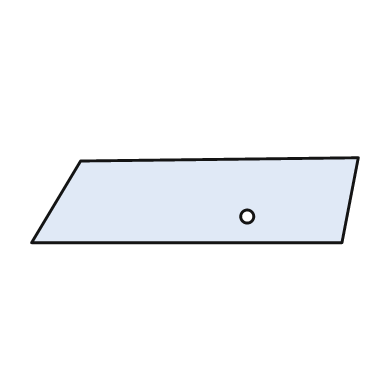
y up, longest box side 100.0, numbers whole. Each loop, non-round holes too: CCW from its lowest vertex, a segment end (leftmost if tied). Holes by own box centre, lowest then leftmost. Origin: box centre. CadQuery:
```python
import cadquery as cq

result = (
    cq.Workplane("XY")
    .moveTo(-50.0, -13.0)
    .lineTo(45.0, -13.0)
    .lineTo(50.0, 13.0)
    .lineTo(-35.0, 12.0)
    .close()
    .moveTo(16.0, -5.0)
    .circle(2.0)
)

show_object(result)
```